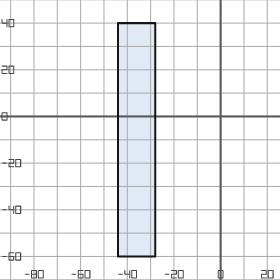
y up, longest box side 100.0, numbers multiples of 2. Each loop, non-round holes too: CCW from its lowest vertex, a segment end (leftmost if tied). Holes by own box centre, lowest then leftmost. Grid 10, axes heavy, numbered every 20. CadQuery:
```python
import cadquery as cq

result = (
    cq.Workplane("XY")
    .moveTo(-44.0, -60.0)
    .lineTo(-28.0, -60.0)
    .lineTo(-28.0, 40.0)
    .lineTo(-44.0, 40.0)
    .close()
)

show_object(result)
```